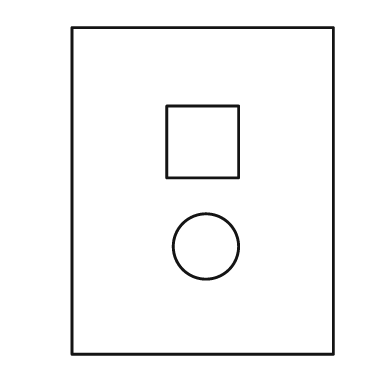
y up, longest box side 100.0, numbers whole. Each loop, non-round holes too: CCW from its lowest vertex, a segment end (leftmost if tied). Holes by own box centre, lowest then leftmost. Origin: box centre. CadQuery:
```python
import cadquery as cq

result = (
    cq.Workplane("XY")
    .moveTo(-40.0, -50.0)
    .lineTo(40.0, -50.0)
    .lineTo(40.0, 50.0)
    .lineTo(-40.0, 50.0)
    .close()
    .moveTo(1.0, -17.0)
    .circle(10.0)
    .moveTo(-11.0, 4.0)
    .lineTo(11.0, 4.0)
    .lineTo(11.0, 26.0)
    .lineTo(-11.0, 26.0)
    .close()
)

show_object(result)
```